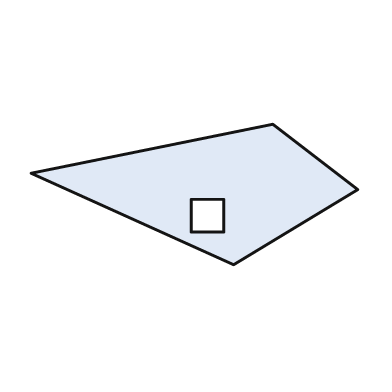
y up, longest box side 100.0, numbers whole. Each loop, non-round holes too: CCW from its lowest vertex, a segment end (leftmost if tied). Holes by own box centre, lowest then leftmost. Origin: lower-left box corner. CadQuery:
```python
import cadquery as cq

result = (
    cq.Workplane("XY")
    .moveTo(62.0, 0.0)
    .lineTo(100.0, 23.0)
    .lineTo(74.0, 43.0)
    .lineTo(0.0, 28.0)
    .close()
    .moveTo(49.0, 10.0)
    .lineTo(59.0, 10.0)
    .lineTo(59.0, 20.0)
    .lineTo(49.0, 20.0)
    .close()
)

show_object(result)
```